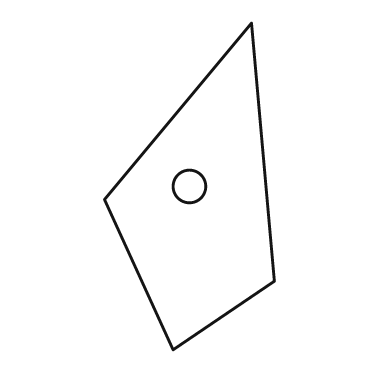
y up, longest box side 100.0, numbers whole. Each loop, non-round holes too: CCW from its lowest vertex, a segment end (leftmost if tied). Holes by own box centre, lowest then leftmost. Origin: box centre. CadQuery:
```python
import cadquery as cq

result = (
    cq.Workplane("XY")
    .moveTo(-5.0, -50.0)
    .lineTo(26.0, -29.0)
    .lineTo(19.0, 50.0)
    .lineTo(-26.0, -4.0)
    .close()
    .moveTo(0.0, 0.0)
    .circle(5.0)
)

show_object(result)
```